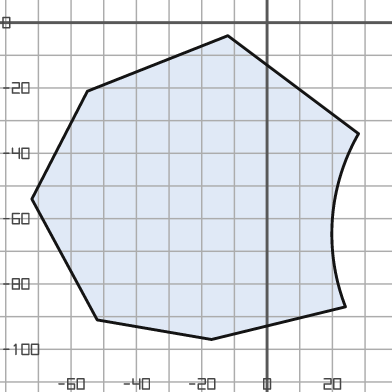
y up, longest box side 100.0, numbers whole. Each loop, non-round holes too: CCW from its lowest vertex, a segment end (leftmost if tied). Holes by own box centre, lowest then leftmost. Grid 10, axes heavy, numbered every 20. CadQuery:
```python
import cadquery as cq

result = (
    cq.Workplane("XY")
    .moveTo(-17.0, -97.0)
    .lineTo(24.0, -87.0)
    .threePointArc((20.0, -60.0), (28.0, -34.0))
    .lineTo(-12.0, -4.0)
    .lineTo(-55.0, -21.0)
    .lineTo(-72.0, -54.0)
    .lineTo(-52.0, -91.0)
    .close()
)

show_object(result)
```